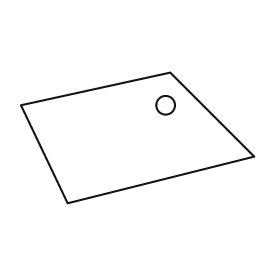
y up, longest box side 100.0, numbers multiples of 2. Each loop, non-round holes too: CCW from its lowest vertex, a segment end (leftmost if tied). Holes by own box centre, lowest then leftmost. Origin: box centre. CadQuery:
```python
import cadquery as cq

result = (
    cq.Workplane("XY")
    .moveTo(-30.0, -28.0)
    .lineTo(50.0, -8.0)
    .lineTo(14.0, 28.0)
    .lineTo(-50.0, 14.0)
    .close()
    .moveTo(12.0, 14.0)
    .circle(4.0)
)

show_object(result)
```